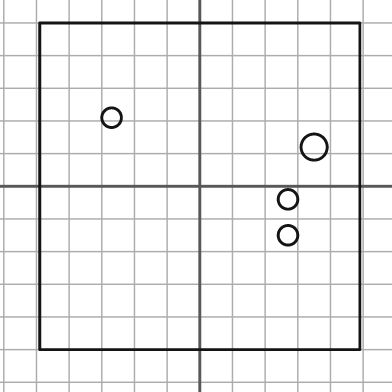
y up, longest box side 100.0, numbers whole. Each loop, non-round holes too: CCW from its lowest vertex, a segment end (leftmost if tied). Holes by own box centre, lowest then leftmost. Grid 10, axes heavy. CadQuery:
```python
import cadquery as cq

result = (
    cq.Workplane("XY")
    .moveTo(-49.0, -50.0)
    .lineTo(49.0, -50.0)
    .lineTo(49.0, 50.0)
    .lineTo(-49.0, 50.0)
    .close()
    .moveTo(27.0, -15.0)
    .circle(3.0)
    .moveTo(27.0, -4.0)
    .circle(3.0)
    .moveTo(35.0, 12.0)
    .circle(4.0)
    .moveTo(-27.0, 21.0)
    .circle(3.0)
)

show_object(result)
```